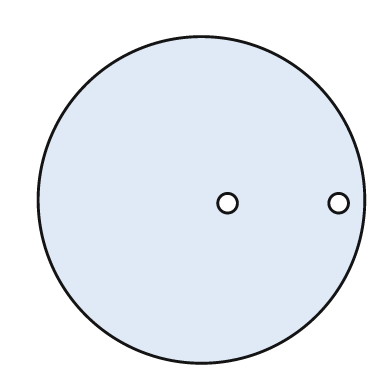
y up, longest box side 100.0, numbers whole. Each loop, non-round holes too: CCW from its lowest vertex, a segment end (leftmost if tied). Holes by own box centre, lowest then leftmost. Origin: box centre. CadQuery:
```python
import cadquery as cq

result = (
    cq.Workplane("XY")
    .moveTo(0.0, 0.0)
    .circle(50.0)
    .moveTo(8.0, -1.0)
    .circle(3.0)
    .moveTo(42.0, -1.0)
    .circle(3.0)
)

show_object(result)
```